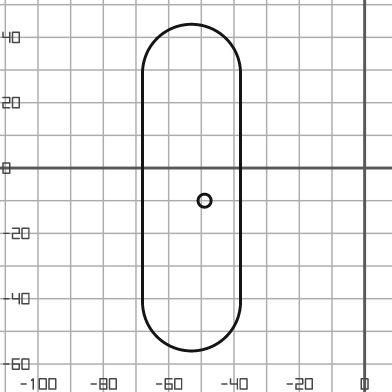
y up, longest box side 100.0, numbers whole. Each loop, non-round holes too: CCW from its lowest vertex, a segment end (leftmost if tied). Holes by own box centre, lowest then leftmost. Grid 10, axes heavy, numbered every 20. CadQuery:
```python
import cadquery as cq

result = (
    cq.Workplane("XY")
    .moveTo(-68.0, -41.0)
    .threePointArc((-53.0, -56.0), (-38.0, -41.0))
    .lineTo(-38.0, 29.0)
    .threePointArc((-53.0, 44.0), (-68.0, 29.0))
    .close()
    .moveTo(-49.0, -10.0)
    .circle(2.0)
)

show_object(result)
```